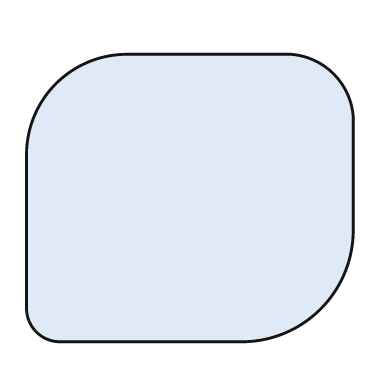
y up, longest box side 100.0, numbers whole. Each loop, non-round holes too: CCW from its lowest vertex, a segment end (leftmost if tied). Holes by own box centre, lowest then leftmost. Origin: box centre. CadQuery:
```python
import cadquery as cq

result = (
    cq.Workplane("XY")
    .moveTo(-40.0, -44.0)
    .lineTo(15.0, -44.0)
    .threePointArc((40.0, -34.0), (50.0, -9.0))
    .lineTo(50.0, 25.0)
    .threePointArc((44.0, 38.0), (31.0, 44.0))
    .lineTo(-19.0, 44.0)
    .threePointArc((-41.0, 35.0), (-50.0, 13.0))
    .lineTo(-50.0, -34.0)
    .threePointArc((-47.0, -41.0), (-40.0, -44.0))
    .close()
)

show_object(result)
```